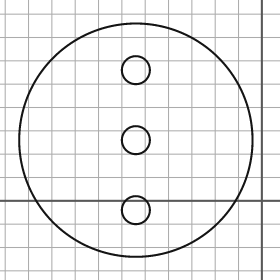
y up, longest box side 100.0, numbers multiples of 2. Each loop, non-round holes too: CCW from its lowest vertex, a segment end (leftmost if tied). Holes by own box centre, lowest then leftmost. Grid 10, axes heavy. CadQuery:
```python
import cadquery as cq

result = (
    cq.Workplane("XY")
    .moveTo(-54.0, 26.0)
    .circle(50.0)
    .moveTo(-54.0, -4.0)
    .circle(6.0)
    .moveTo(-54.0, 26.0)
    .circle(6.0)
    .moveTo(-54.0, 56.0)
    .circle(6.0)
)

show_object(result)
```